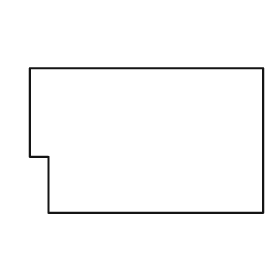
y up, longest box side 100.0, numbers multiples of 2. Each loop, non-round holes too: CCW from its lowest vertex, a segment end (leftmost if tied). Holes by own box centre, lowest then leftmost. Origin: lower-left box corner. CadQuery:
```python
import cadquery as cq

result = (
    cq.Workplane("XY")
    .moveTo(8.0, 0.0)
    .lineTo(100.0, 0.0)
    .lineTo(100.0, 62.0)
    .lineTo(0.0, 62.0)
    .lineTo(0.0, 24.0)
    .lineTo(8.0, 24.0)
    .close()
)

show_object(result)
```